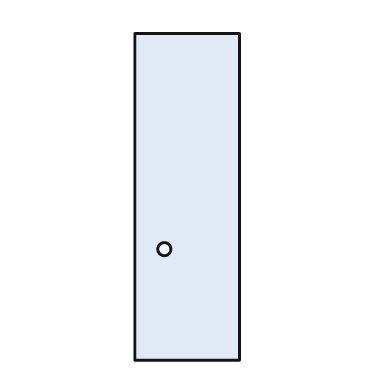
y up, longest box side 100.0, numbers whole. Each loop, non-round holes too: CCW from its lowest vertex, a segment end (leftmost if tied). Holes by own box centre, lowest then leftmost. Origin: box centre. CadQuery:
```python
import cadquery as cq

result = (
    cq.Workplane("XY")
    .moveTo(-16.0, -50.0)
    .lineTo(16.0, -50.0)
    .lineTo(16.0, 50.0)
    .lineTo(-16.0, 50.0)
    .close()
    .moveTo(-7.0, -16.0)
    .circle(2.0)
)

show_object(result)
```